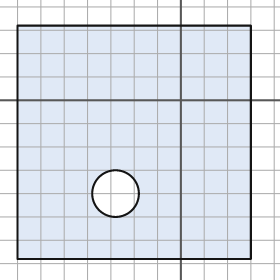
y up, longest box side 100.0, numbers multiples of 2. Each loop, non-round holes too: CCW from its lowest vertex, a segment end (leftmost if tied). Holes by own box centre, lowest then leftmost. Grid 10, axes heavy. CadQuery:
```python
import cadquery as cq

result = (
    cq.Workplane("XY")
    .moveTo(-70.0, -68.0)
    .lineTo(30.0, -68.0)
    .lineTo(30.0, 32.0)
    .lineTo(-70.0, 32.0)
    .close()
    .moveTo(-28.0, -40.0)
    .circle(10.0)
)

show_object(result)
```